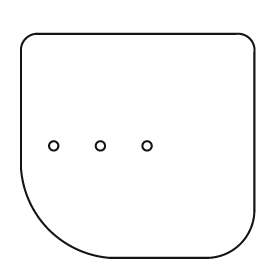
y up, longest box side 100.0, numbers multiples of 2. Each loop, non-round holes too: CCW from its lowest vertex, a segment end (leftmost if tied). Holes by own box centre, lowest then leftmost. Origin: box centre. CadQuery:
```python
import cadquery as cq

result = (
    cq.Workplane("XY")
    .moveTo(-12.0, -48.0)
    .lineTo(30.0, -48.0)
    .threePointArc((44.0, -42.0), (50.0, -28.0))
    .lineTo(50.0, 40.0)
    .threePointArc((48.0, 46.0), (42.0, 48.0))
    .lineTo(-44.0, 48.0)
    .threePointArc((-48.0, 46.0), (-50.0, 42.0))
    .lineTo(-50.0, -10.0)
    .threePointArc((-38.0, -36.0), (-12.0, -48.0))
    .close()
    .moveTo(-36.0, 0.0)
    .circle(2.0)
    .moveTo(-16.0, 0.0)
    .circle(2.0)
    .moveTo(4.0, 0.0)
    .circle(2.0)
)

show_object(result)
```